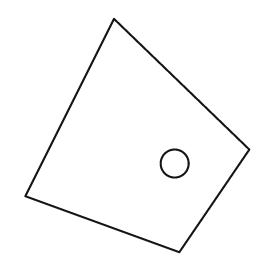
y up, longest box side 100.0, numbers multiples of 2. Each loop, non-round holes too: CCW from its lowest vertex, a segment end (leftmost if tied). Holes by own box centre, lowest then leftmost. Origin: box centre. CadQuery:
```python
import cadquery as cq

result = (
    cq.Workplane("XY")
    .moveTo(18.0, -50.0)
    .lineTo(48.0, -6.0)
    .lineTo(-10.0, 50.0)
    .lineTo(-48.0, -26.0)
    .close()
    .moveTo(16.0, -12.0)
    .circle(6.0)
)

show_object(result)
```